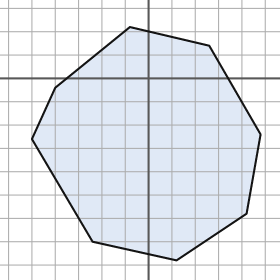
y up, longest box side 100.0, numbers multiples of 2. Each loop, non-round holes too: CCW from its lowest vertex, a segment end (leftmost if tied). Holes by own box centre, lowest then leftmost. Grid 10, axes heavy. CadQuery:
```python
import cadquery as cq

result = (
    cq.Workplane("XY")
    .moveTo(12.0, -78.0)
    .lineTo(42.0, -58.0)
    .lineTo(48.0, -24.0)
    .lineTo(26.0, 14.0)
    .lineTo(-8.0, 22.0)
    .lineTo(-40.0, -4.0)
    .lineTo(-50.0, -26.0)
    .lineTo(-24.0, -70.0)
    .close()
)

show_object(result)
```